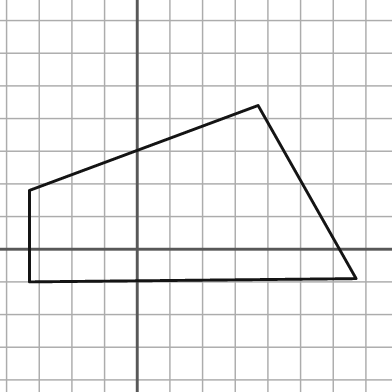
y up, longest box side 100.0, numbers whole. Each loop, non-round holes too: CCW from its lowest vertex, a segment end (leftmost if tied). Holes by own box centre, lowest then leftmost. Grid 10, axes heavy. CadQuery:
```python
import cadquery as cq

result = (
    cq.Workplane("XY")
    .moveTo(-33.0, -10.0)
    .lineTo(67.0, -9.0)
    .lineTo(37.0, 44.0)
    .lineTo(-33.0, 18.0)
    .close()
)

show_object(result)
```